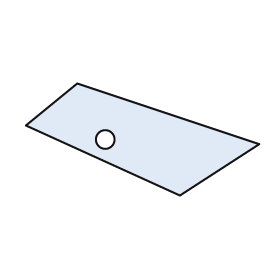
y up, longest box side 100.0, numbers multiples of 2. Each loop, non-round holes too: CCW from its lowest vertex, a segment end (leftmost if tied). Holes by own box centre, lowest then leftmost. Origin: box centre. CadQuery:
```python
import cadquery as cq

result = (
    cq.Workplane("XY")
    .moveTo(16.0, -24.0)
    .lineTo(50.0, -2.0)
    .lineTo(-28.0, 24.0)
    .lineTo(-50.0, 6.0)
    .close()
    .moveTo(-16.0, 0.0)
    .circle(4.0)
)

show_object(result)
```